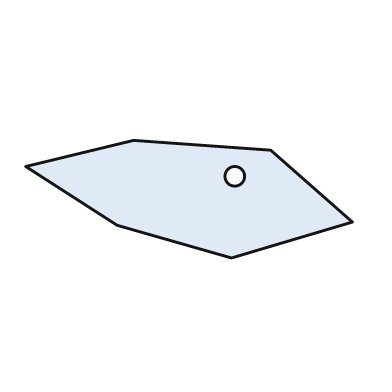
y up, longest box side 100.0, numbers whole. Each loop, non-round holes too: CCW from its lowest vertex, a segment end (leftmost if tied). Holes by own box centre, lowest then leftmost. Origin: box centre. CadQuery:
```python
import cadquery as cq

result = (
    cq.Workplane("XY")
    .moveTo(13.0, -18.0)
    .lineTo(50.0, -7.0)
    .lineTo(25.0, 15.0)
    .lineTo(-17.0, 18.0)
    .lineTo(-50.0, 10.0)
    .lineTo(-22.0, -8.0)
    .close()
    .moveTo(14.0, 7.0)
    .circle(3.0)
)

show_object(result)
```